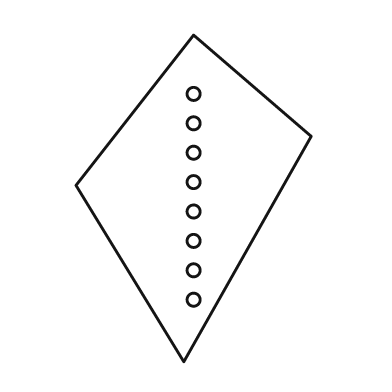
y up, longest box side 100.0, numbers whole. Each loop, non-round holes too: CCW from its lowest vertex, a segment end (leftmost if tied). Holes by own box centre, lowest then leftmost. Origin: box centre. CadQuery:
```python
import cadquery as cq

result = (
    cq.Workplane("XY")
    .moveTo(-3.0, -50.0)
    .lineTo(36.0, 19.0)
    .lineTo(0.0, 50.0)
    .lineTo(-36.0, 4.0)
    .close()
    .moveTo(0.0, -31.0)
    .circle(2.0)
    .moveTo(0.0, -22.0)
    .circle(2.0)
    .moveTo(0.0, -13.0)
    .circle(2.0)
    .moveTo(0.0, -4.0)
    .circle(2.0)
    .moveTo(0.0, 5.0)
    .circle(2.0)
    .moveTo(0.0, 14.0)
    .circle(2.0)
    .moveTo(0.0, 23.0)
    .circle(2.0)
    .moveTo(0.0, 32.0)
    .circle(2.0)
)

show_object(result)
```